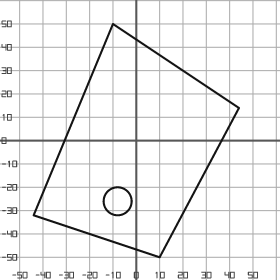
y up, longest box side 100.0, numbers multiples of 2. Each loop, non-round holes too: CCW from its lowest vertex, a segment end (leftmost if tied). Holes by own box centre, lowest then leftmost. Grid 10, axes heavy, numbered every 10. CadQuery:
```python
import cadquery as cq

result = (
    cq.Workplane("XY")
    .moveTo(10.0, -50.0)
    .lineTo(44.0, 14.0)
    .lineTo(-10.0, 50.0)
    .lineTo(-44.0, -32.0)
    .close()
    .moveTo(-8.0, -26.0)
    .circle(6.0)
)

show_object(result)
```